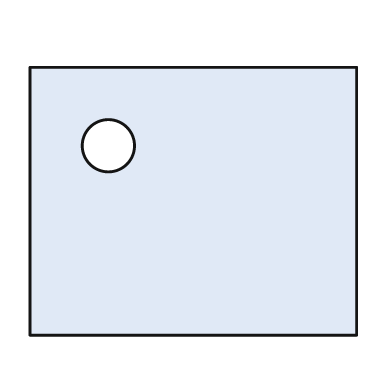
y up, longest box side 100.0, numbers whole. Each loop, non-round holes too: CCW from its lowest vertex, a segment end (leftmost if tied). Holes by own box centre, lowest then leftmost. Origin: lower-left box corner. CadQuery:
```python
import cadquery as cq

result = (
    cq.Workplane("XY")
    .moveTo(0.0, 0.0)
    .lineTo(100.0, 0.0)
    .lineTo(100.0, 82.0)
    .lineTo(0.0, 82.0)
    .close()
    .moveTo(24.0, 58.0)
    .circle(8.0)
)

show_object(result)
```